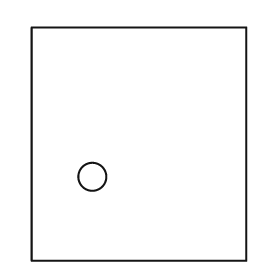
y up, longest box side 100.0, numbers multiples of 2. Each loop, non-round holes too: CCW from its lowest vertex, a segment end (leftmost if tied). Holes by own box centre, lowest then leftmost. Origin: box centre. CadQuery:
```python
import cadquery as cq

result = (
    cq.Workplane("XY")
    .moveTo(-46.0, -50.0)
    .lineTo(46.0, -50.0)
    .lineTo(46.0, 50.0)
    .lineTo(-46.0, 50.0)
    .close()
    .moveTo(-20.0, -14.0)
    .circle(6.0)
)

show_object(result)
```